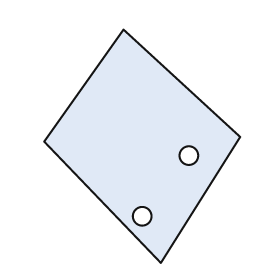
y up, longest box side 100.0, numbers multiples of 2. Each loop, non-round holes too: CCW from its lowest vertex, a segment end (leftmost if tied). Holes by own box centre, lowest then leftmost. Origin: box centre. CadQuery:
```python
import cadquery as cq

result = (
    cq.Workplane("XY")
    .moveTo(8.0, -50.0)
    .lineTo(42.0, 4.0)
    .lineTo(-8.0, 50.0)
    .lineTo(-42.0, 2.0)
    .close()
    .moveTo(0.0, -30.0)
    .circle(4.0)
    .moveTo(20.0, -4.0)
    .circle(4.0)
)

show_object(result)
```